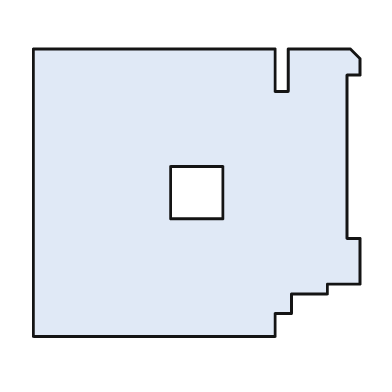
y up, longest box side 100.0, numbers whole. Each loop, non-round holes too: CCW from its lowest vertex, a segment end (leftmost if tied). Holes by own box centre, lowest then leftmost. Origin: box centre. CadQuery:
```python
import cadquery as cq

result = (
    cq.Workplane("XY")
    .moveTo(-50.0, -44.0)
    .lineTo(24.0, -44.0)
    .lineTo(24.0, -37.0)
    .lineTo(29.0, -37.0)
    .lineTo(29.0, -31.0)
    .lineTo(40.0, -31.0)
    .lineTo(40.0, -28.0)
    .lineTo(50.0, -28.0)
    .lineTo(50.0, -14.0)
    .lineTo(46.0, -14.0)
    .lineTo(46.0, 36.0)
    .lineTo(50.0, 36.0)
    .lineTo(50.0, 41.0)
    .lineTo(47.0, 44.0)
    .lineTo(28.0, 44.0)
    .lineTo(28.0, 31.0)
    .lineTo(24.0, 31.0)
    .lineTo(24.0, 44.0)
    .lineTo(-50.0, 44.0)
    .close()
    .moveTo(-8.0, -8.0)
    .lineTo(8.0, -8.0)
    .lineTo(8.0, 8.0)
    .lineTo(-8.0, 8.0)
    .close()
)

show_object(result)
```